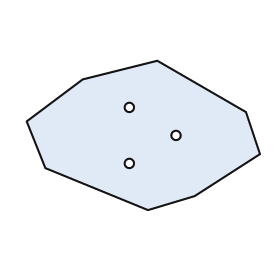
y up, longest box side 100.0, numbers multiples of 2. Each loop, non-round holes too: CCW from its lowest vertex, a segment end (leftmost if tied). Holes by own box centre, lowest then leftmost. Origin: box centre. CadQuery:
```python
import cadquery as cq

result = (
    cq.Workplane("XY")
    .moveTo(2.0, -32.0)
    .lineTo(22.0, -26.0)
    .lineTo(50.0, -8.0)
    .lineTo(44.0, 10.0)
    .lineTo(6.0, 32.0)
    .lineTo(-26.0, 24.0)
    .lineTo(-50.0, 6.0)
    .lineTo(-42.0, -14.0)
    .close()
    .moveTo(-6.0, -12.0)
    .circle(2.0)
    .moveTo(14.0, 0.0)
    .circle(2.0)
    .moveTo(-6.0, 12.0)
    .circle(2.0)
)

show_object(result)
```